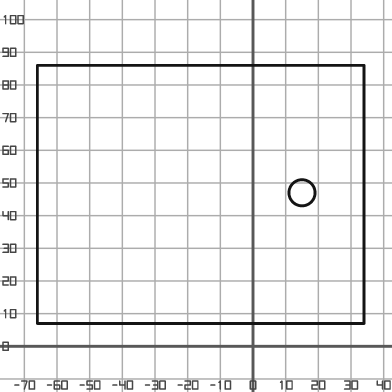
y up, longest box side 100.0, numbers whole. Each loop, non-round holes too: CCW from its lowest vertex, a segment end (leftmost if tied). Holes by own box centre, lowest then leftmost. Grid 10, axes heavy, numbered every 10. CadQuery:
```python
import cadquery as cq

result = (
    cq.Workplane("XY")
    .moveTo(-66.0, 7.0)
    .lineTo(34.0, 7.0)
    .lineTo(34.0, 86.0)
    .lineTo(-66.0, 86.0)
    .close()
    .moveTo(15.0, 47.0)
    .circle(4.0)
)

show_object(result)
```